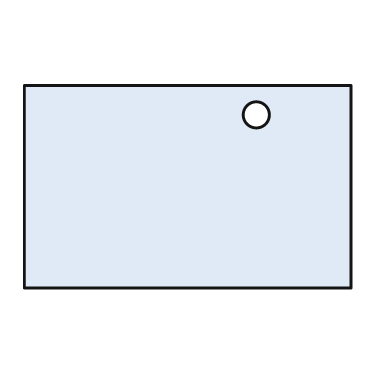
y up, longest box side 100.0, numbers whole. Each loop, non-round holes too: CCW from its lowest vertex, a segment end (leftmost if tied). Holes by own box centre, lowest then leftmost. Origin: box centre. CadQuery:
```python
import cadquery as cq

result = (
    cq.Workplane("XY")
    .moveTo(-50.0, -31.0)
    .lineTo(50.0, -31.0)
    .lineTo(50.0, 31.0)
    .lineTo(-50.0, 31.0)
    .close()
    .moveTo(21.0, 22.0)
    .circle(4.0)
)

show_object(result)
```